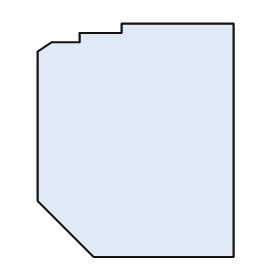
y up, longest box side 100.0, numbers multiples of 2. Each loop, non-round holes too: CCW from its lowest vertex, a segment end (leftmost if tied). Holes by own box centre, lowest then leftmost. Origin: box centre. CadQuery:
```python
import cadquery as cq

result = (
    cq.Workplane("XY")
    .moveTo(-18.0, -50.0)
    .lineTo(42.0, -50.0)
    .lineTo(42.0, 50.0)
    .lineTo(-6.0, 50.0)
    .lineTo(-6.0, 46.0)
    .lineTo(-24.0, 46.0)
    .lineTo(-24.0, 42.0)
    .lineTo(-36.0, 42.0)
    .lineTo(-42.0, 38.0)
    .lineTo(-42.0, -26.0)
    .close()
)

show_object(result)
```